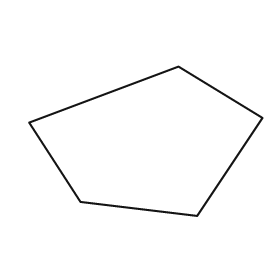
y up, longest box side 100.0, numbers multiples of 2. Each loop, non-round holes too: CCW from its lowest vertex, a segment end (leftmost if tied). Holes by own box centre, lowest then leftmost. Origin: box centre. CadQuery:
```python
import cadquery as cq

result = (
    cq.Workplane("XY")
    .moveTo(22.0, -32.0)
    .lineTo(50.0, 10.0)
    .lineTo(14.0, 32.0)
    .lineTo(-50.0, 8.0)
    .lineTo(-28.0, -26.0)
    .close()
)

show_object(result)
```